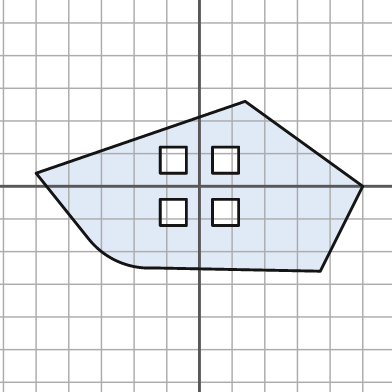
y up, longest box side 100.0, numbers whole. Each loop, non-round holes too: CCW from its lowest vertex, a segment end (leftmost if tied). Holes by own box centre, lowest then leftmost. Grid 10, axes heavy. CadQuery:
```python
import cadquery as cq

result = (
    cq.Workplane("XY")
    .moveTo(37.0, -26.0)
    .lineTo(50.0, 0.0)
    .lineTo(14.0, 26.0)
    .lineTo(-50.0, 4.0)
    .lineTo(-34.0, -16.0)
    .threePointArc((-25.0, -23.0), (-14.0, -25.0))
    .close()
    .moveTo(-12.0, -12.0)
    .lineTo(-4.0, -12.0)
    .lineTo(-4.0, -4.0)
    .lineTo(-12.0, -4.0)
    .close()
    .moveTo(4.0, -12.0)
    .lineTo(12.0, -12.0)
    .lineTo(12.0, -4.0)
    .lineTo(4.0, -4.0)
    .close()
    .moveTo(-12.0, 4.0)
    .lineTo(-4.0, 4.0)
    .lineTo(-4.0, 12.0)
    .lineTo(-12.0, 12.0)
    .close()
    .moveTo(4.0, 4.0)
    .lineTo(12.0, 4.0)
    .lineTo(12.0, 12.0)
    .lineTo(4.0, 12.0)
    .close()
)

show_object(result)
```